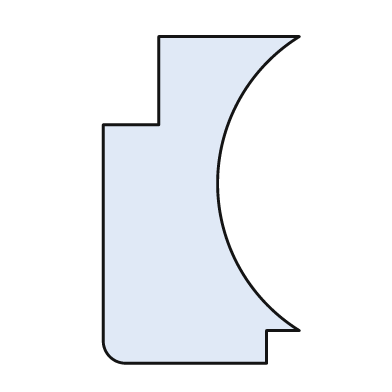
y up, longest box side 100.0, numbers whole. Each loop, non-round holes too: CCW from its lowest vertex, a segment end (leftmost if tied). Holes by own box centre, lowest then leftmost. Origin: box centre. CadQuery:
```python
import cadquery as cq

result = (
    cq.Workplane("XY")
    .moveTo(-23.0, -50.0)
    .lineTo(20.0, -50.0)
    .lineTo(20.0, -40.0)
    .lineTo(30.0, -40.0)
    .threePointArc((5.0, 5.0), (30.0, 50.0))
    .lineTo(-13.0, 50.0)
    .lineTo(-13.0, 23.0)
    .lineTo(-30.0, 23.0)
    .lineTo(-30.0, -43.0)
    .threePointArc((-28.0, -48.0), (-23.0, -50.0))
    .close()
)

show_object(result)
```